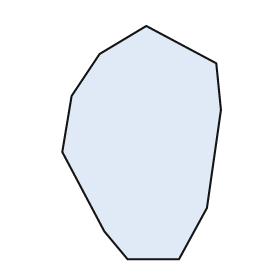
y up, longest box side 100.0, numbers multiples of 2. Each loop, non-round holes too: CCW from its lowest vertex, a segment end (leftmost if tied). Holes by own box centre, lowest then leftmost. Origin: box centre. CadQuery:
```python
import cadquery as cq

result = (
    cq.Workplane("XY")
    .moveTo(-6.0, -50.0)
    .lineTo(16.0, -50.0)
    .lineTo(28.0, -28.0)
    .lineTo(34.0, 14.0)
    .lineTo(32.0, 34.0)
    .lineTo(2.0, 50.0)
    .lineTo(-18.0, 38.0)
    .lineTo(-30.0, 20.0)
    .lineTo(-34.0, -4.0)
    .lineTo(-16.0, -38.0)
    .close()
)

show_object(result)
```